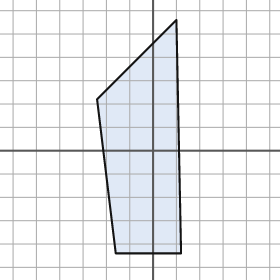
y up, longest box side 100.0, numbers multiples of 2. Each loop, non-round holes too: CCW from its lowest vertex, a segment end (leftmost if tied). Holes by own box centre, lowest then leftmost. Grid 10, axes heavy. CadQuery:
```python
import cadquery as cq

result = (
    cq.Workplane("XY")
    .moveTo(-16.0, -44.0)
    .lineTo(12.0, -44.0)
    .lineTo(10.0, 56.0)
    .lineTo(-24.0, 22.0)
    .close()
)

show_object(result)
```